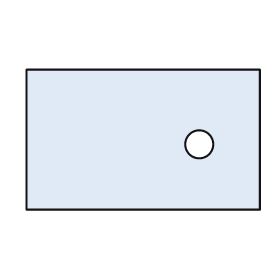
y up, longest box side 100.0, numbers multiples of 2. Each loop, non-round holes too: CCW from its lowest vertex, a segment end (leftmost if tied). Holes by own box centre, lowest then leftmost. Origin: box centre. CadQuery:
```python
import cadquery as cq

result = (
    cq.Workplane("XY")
    .moveTo(-50.0, -30.0)
    .lineTo(50.0, -30.0)
    .lineTo(50.0, 30.0)
    .lineTo(-50.0, 30.0)
    .close()
    .moveTo(24.0, -2.0)
    .circle(6.0)
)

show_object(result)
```